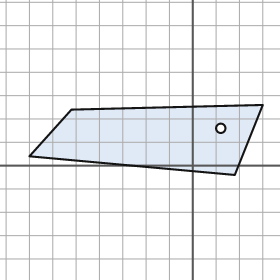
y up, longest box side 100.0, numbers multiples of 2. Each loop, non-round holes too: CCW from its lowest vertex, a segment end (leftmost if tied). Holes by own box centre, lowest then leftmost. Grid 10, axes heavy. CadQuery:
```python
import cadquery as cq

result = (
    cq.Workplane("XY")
    .moveTo(18.0, -4.0)
    .lineTo(30.0, 26.0)
    .lineTo(-52.0, 24.0)
    .lineTo(-70.0, 4.0)
    .close()
    .moveTo(12.0, 16.0)
    .circle(2.0)
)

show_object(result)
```